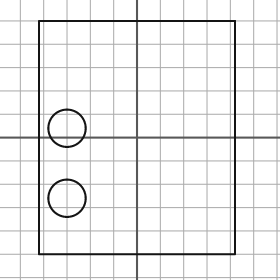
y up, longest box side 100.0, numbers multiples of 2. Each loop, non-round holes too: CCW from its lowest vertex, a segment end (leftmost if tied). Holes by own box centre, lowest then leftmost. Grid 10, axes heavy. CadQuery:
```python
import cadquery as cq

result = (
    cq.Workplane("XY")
    .moveTo(-42.0, -50.0)
    .lineTo(42.0, -50.0)
    .lineTo(42.0, 50.0)
    .lineTo(-42.0, 50.0)
    .close()
    .moveTo(-30.0, -26.0)
    .circle(8.0)
    .moveTo(-30.0, 4.0)
    .circle(8.0)
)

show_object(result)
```